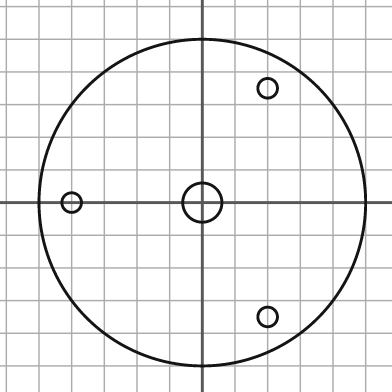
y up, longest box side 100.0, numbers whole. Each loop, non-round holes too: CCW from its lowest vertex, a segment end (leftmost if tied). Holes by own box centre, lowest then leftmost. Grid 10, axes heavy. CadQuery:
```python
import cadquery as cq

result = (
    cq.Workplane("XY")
    .moveTo(0.0, 0.0)
    .circle(50.0)
    .moveTo(20.0, -35.0)
    .circle(3.0)
    .moveTo(-40.0, 0.0)
    .circle(3.0)
    .moveTo(0.0, 0.0)
    .circle(6.0)
    .moveTo(20.0, 35.0)
    .circle(3.0)
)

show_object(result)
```